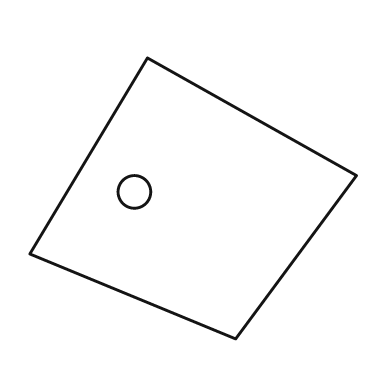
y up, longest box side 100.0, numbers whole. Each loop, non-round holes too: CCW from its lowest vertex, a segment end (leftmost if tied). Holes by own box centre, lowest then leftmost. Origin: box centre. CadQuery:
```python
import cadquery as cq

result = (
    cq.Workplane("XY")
    .moveTo(13.0, -43.0)
    .lineTo(50.0, 7.0)
    .lineTo(-14.0, 43.0)
    .lineTo(-50.0, -17.0)
    .close()
    .moveTo(-18.0, 2.0)
    .circle(5.0)
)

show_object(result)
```